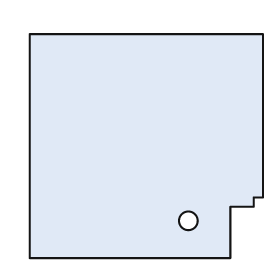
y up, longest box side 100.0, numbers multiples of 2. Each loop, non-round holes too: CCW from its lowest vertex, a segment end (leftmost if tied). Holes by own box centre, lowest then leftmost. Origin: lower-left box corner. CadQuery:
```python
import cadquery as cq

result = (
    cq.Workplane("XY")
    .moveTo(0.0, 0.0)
    .lineTo(86.0, 0.0)
    .lineTo(86.0, 22.0)
    .lineTo(96.0, 22.0)
    .lineTo(96.0, 26.0)
    .lineTo(100.0, 26.0)
    .lineTo(100.0, 96.0)
    .lineTo(0.0, 96.0)
    .close()
    .moveTo(68.0, 16.0)
    .circle(4.0)
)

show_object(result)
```